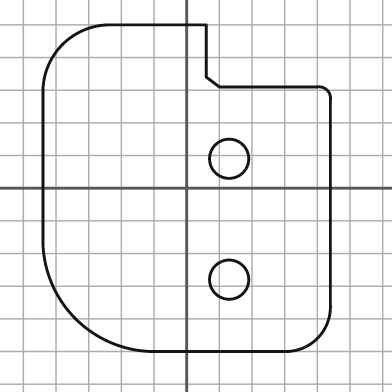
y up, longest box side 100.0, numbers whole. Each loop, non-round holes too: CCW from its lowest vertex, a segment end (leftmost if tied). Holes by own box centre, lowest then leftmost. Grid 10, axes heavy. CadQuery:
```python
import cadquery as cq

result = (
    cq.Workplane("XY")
    .moveTo(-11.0, -50.0)
    .lineTo(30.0, -50.0)
    .threePointArc((40.0, -46.0), (44.0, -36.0))
    .lineTo(44.0, 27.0)
    .threePointArc((43.0, 30.0), (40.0, 31.0))
    .lineTo(10.0, 31.0)
    .lineTo(6.0, 34.0)
    .lineTo(6.0, 50.0)
    .lineTo(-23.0, 50.0)
    .threePointArc((-38.0, 44.0), (-44.0, 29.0))
    .lineTo(-44.0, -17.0)
    .threePointArc((-34.0, -40.0), (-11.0, -50.0))
    .close()
    .moveTo(13.0, -28.0)
    .circle(6.0)
    .moveTo(13.0, 9.0)
    .circle(6.0)
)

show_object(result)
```